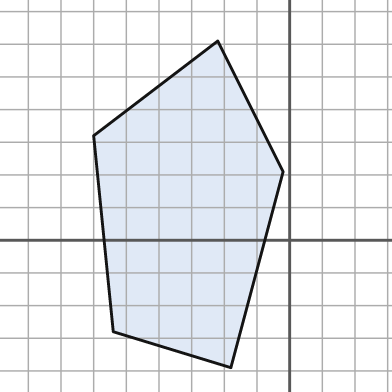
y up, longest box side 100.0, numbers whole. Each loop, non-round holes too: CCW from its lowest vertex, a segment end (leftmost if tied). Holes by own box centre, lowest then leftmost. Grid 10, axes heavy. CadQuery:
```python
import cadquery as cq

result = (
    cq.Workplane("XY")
    .moveTo(-18.0, -39.0)
    .lineTo(-2.0, 21.0)
    .lineTo(-22.0, 61.0)
    .lineTo(-60.0, 32.0)
    .lineTo(-54.0, -28.0)
    .close()
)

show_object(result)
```